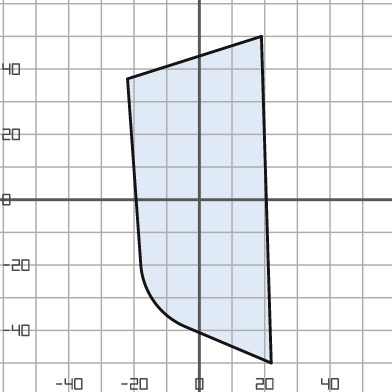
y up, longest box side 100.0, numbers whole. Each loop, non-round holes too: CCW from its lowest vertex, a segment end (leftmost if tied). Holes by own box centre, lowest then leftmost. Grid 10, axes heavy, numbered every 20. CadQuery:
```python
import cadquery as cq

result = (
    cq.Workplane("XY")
    .moveTo(22.0, -50.0)
    .lineTo(19.0, 50.0)
    .lineTo(-22.0, 37.0)
    .lineTo(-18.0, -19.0)
    .threePointArc((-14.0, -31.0), (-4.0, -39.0))
    .close()
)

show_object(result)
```